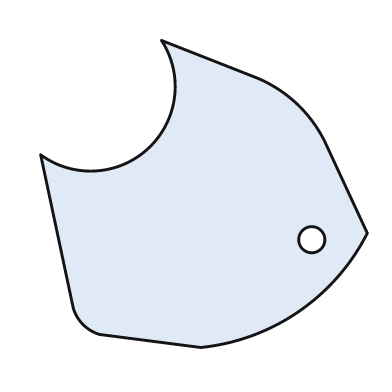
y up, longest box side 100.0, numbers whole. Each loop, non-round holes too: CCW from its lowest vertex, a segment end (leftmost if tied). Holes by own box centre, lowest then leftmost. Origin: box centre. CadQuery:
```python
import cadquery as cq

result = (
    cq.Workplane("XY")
    .moveTo(-1.0, -47.0)
    .threePointArc((29.0, -36.0), (50.0, -12.0))
    .lineTo(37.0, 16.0)
    .threePointArc((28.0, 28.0), (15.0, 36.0))
    .lineTo(-13.0, 47.0)
    .threePointArc((-17.0, 14.0), (-50.0, 12.0))
    .lineTo(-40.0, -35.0)
    .threePointArc((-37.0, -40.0), (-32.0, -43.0))
    .close()
    .moveTo(33.0, -14.0)
    .circle(4.0)
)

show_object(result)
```